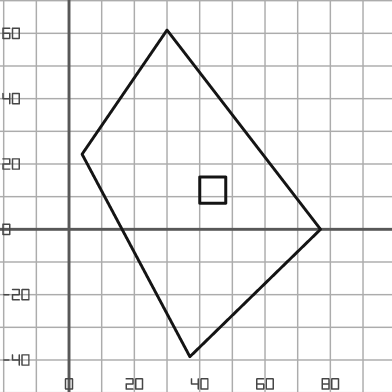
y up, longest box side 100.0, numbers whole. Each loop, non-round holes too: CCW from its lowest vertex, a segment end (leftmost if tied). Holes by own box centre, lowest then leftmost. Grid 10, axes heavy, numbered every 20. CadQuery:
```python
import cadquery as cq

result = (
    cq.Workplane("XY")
    .moveTo(37.0, -39.0)
    .lineTo(77.0, 0.0)
    .lineTo(30.0, 61.0)
    .lineTo(4.0, 23.0)
    .close()
    .moveTo(40.0, 8.0)
    .lineTo(48.0, 8.0)
    .lineTo(48.0, 16.0)
    .lineTo(40.0, 16.0)
    .close()
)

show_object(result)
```